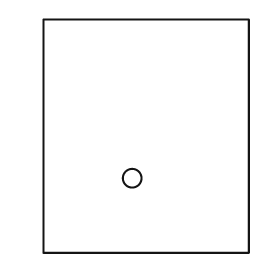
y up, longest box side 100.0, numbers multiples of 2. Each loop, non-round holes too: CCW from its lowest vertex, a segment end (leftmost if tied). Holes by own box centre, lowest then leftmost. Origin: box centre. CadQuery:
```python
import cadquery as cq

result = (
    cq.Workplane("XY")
    .moveTo(-44.0, -50.0)
    .lineTo(44.0, -50.0)
    .lineTo(44.0, 50.0)
    .lineTo(-44.0, 50.0)
    .close()
    .moveTo(-6.0, -18.0)
    .circle(4.0)
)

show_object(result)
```